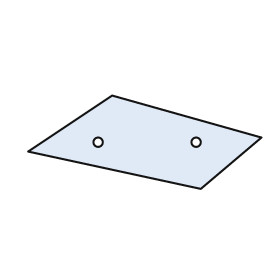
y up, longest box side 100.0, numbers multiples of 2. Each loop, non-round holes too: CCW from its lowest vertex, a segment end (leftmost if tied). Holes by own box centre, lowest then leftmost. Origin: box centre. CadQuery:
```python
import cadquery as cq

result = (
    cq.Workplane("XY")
    .moveTo(24.0, -20.0)
    .lineTo(50.0, 2.0)
    .lineTo(-14.0, 20.0)
    .lineTo(-50.0, -4.0)
    .close()
    .moveTo(-20.0, 0.0)
    .circle(2.0)
    .moveTo(22.0, 0.0)
    .circle(2.0)
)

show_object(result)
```